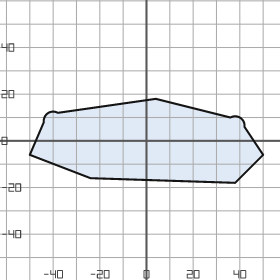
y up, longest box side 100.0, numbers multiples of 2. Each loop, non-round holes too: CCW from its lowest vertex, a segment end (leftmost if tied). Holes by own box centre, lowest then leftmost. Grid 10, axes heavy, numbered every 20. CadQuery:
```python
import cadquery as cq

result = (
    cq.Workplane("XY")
    .moveTo(38.0, -18.0)
    .lineTo(50.0, -6.0)
    .lineTo(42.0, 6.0)
    .threePointArc((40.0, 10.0), (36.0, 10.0))
    .lineTo(4.0, 18.0)
    .lineTo(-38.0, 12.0)
    .threePointArc((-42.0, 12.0), (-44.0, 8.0))
    .lineTo(-50.0, -6.0)
    .lineTo(-24.0, -16.0)
    .close()
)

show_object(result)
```